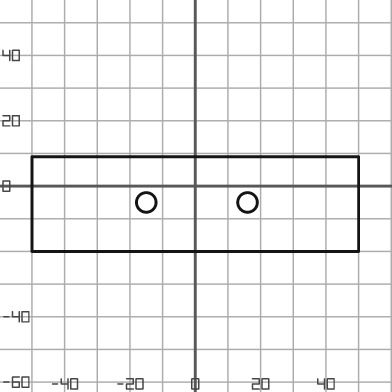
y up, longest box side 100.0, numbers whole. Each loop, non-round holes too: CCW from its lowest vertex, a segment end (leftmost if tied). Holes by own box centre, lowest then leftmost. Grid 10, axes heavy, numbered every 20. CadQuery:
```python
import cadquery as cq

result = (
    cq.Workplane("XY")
    .moveTo(-50.0, -20.0)
    .lineTo(50.0, -20.0)
    .lineTo(50.0, 9.0)
    .lineTo(-50.0, 9.0)
    .close()
    .moveTo(-15.0, -5.0)
    .circle(3.0)
    .moveTo(16.0, -5.0)
    .circle(3.0)
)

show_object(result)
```